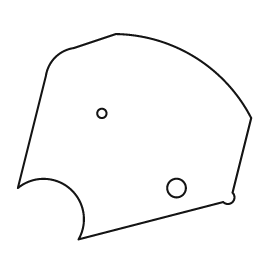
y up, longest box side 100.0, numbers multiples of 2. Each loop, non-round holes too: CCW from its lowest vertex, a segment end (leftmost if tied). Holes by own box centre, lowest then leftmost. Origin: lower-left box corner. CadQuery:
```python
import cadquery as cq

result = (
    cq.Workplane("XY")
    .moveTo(26.0, 0.0)
    .lineTo(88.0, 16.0)
    .threePointArc((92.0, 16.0), (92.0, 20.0))
    .lineTo(100.0, 52.0)
    .threePointArc((76.0, 78.0), (42.0, 88.0))
    .lineTo(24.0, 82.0)
    .threePointArc((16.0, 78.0), (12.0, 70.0))
    .lineTo(0.0, 22.0)
    .threePointArc((22.0, 22.0), (26.0, 0.0))
    .close()
    .moveTo(68.0, 22.0)
    .circle(4.0)
    .moveTo(36.0, 54.0)
    .circle(2.0)
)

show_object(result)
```